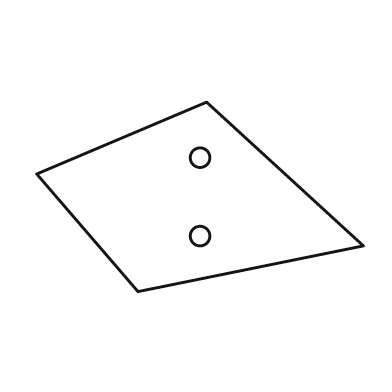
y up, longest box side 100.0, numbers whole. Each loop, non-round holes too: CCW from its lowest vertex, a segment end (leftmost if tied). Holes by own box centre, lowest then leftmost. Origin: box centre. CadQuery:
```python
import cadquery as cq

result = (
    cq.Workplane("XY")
    .moveTo(-19.0, -29.0)
    .lineTo(50.0, -15.0)
    .lineTo(2.0, 29.0)
    .lineTo(-50.0, 7.0)
    .close()
    .moveTo(0.0, -12.0)
    .circle(3.0)
    .moveTo(0.0, 12.0)
    .circle(3.0)
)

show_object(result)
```